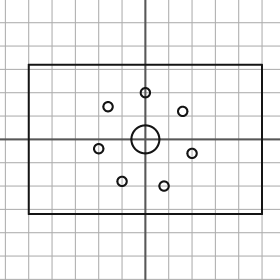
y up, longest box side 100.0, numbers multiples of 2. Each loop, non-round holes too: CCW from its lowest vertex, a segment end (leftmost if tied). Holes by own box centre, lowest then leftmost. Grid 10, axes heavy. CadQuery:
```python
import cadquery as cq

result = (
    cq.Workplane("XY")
    .moveTo(-50.0, -32.0)
    .lineTo(50.0, -32.0)
    .lineTo(50.0, 32.0)
    .lineTo(-50.0, 32.0)
    .close()
    .moveTo(8.0, -20.0)
    .circle(2.0)
    .moveTo(-10.0, -18.0)
    .circle(2.0)
    .moveTo(20.0, -6.0)
    .circle(2.0)
    .moveTo(-20.0, -4.0)
    .circle(2.0)
    .moveTo(0.0, 0.0)
    .circle(6.0)
    .moveTo(16.0, 12.0)
    .circle(2.0)
    .moveTo(-16.0, 14.0)
    .circle(2.0)
    .moveTo(0.0, 20.0)
    .circle(2.0)
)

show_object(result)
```